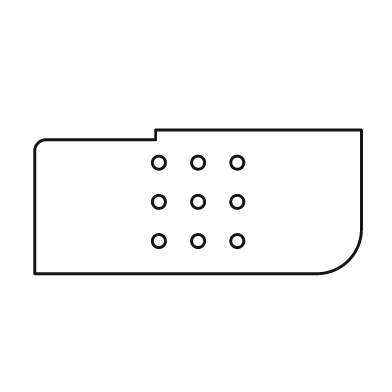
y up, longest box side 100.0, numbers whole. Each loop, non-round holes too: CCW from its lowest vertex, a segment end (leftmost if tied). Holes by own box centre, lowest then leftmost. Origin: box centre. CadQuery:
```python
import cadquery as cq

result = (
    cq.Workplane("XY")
    .moveTo(-50.0, -22.0)
    .lineTo(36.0, -22.0)
    .threePointArc((46.0, -18.0), (50.0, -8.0))
    .lineTo(50.0, 22.0)
    .lineTo(-13.0, 22.0)
    .lineTo(-13.0, 19.0)
    .lineTo(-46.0, 19.0)
    .threePointArc((-49.0, 18.0), (-50.0, 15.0))
    .close()
    .moveTo(-12.0, -12.0)
    .circle(2.0)
    .moveTo(0.0, -12.0)
    .circle(2.0)
    .moveTo(12.0, -12.0)
    .circle(2.0)
    .moveTo(-12.0, 0.0)
    .circle(2.0)
    .moveTo(0.0, 0.0)
    .circle(2.0)
    .moveTo(12.0, 0.0)
    .circle(2.0)
    .moveTo(-12.0, 12.0)
    .circle(2.0)
    .moveTo(0.0, 12.0)
    .circle(2.0)
    .moveTo(12.0, 12.0)
    .circle(2.0)
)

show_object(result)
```